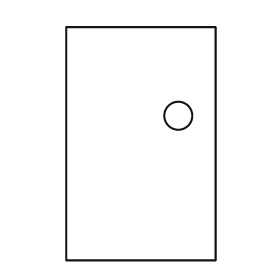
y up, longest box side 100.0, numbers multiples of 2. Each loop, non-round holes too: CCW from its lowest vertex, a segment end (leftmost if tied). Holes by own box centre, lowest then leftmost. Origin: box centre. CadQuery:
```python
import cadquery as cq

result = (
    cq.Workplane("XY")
    .moveTo(-32.0, -50.0)
    .lineTo(32.0, -50.0)
    .lineTo(32.0, 50.0)
    .lineTo(-32.0, 50.0)
    .close()
    .moveTo(16.0, 12.0)
    .circle(6.0)
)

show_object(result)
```